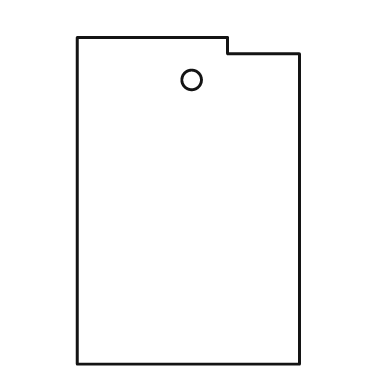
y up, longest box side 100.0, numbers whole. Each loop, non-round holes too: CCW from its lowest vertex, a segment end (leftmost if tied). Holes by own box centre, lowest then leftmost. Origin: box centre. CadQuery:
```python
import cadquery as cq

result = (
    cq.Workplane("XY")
    .moveTo(-34.0, -50.0)
    .lineTo(34.0, -50.0)
    .lineTo(34.0, 45.0)
    .lineTo(12.0, 45.0)
    .lineTo(12.0, 50.0)
    .lineTo(-34.0, 50.0)
    .close()
    .moveTo(1.0, 37.0)
    .circle(3.0)
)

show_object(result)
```